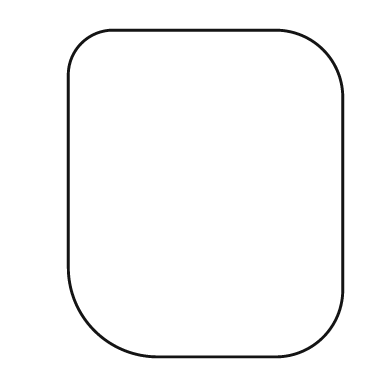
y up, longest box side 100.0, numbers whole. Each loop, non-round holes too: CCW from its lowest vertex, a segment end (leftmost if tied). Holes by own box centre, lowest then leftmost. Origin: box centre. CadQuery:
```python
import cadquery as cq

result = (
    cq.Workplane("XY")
    .moveTo(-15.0, -50.0)
    .lineTo(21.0, -50.0)
    .threePointArc((36.0, -44.0), (42.0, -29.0))
    .lineTo(42.0, 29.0)
    .threePointArc((36.0, 44.0), (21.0, 50.0))
    .lineTo(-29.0, 50.0)
    .threePointArc((-38.0, 46.0), (-42.0, 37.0))
    .lineTo(-42.0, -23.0)
    .threePointArc((-34.0, -42.0), (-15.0, -50.0))
    .close()
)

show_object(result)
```